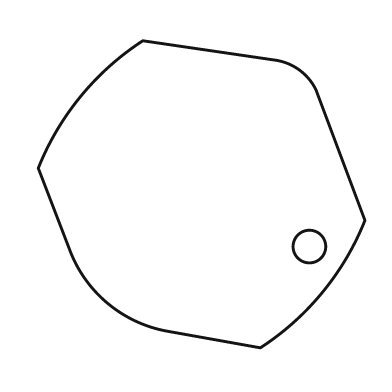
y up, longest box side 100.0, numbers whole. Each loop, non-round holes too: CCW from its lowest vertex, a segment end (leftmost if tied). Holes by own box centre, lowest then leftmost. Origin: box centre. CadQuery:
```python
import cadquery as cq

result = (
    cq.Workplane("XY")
    .moveTo(18.0, -47.0)
    .threePointArc((37.0, -30.0), (50.0, -8.0))
    .lineTo(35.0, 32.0)
    .threePointArc((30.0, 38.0), (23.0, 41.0))
    .lineTo(-18.0, 47.0)
    .threePointArc((-37.0, 30.0), (-50.0, 8.0))
    .lineTo(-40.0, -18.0)
    .threePointArc((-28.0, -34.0), (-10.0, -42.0))
    .close()
    .moveTo(33.0, -16.0)
    .circle(5.0)
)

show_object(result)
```